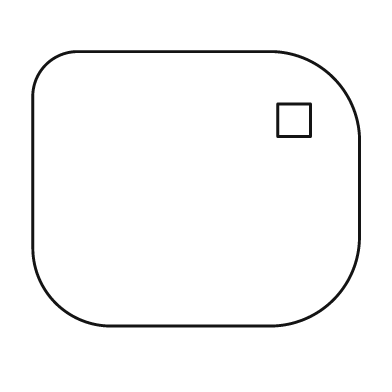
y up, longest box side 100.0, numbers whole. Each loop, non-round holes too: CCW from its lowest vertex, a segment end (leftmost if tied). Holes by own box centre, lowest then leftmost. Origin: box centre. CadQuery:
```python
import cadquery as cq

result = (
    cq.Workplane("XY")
    .moveTo(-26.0, -42.0)
    .lineTo(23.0, -42.0)
    .threePointArc((42.0, -34.0), (50.0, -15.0))
    .lineTo(50.0, 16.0)
    .threePointArc((42.0, 34.0), (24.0, 42.0))
    .lineTo(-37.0, 42.0)
    .threePointArc((-46.0, 38.0), (-50.0, 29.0))
    .lineTo(-50.0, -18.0)
    .threePointArc((-43.0, -35.0), (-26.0, -42.0))
    .close()
    .moveTo(25.0, 16.0)
    .lineTo(35.0, 16.0)
    .lineTo(35.0, 26.0)
    .lineTo(25.0, 26.0)
    .close()
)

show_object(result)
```